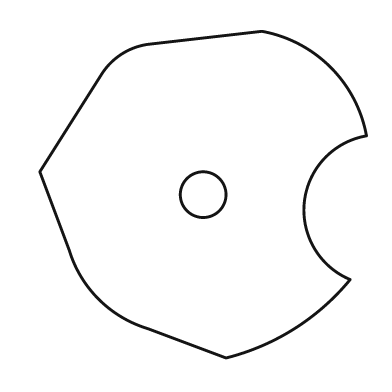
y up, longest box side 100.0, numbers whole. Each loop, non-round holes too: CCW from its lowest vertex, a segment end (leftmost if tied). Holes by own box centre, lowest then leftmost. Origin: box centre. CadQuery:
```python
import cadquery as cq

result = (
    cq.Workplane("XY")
    .moveTo(7.0, -50.0)
    .threePointArc((28.0, -41.0), (45.0, -26.0))
    .threePointArc((31.0, -2.0), (50.0, 18.0))
    .threePointArc((39.0, 39.0), (18.0, 50.0))
    .lineTo(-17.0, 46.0)
    .threePointArc((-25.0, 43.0), (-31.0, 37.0))
    .lineTo(-50.0, 7.0)
    .lineTo(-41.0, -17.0)
    .threePointArc((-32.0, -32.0), (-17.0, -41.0))
    .close()
    .moveTo(0.0, 0.0)
    .circle(7.0)
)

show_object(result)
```